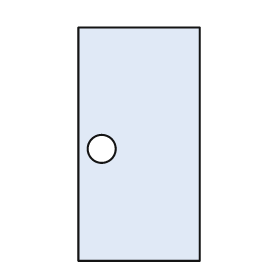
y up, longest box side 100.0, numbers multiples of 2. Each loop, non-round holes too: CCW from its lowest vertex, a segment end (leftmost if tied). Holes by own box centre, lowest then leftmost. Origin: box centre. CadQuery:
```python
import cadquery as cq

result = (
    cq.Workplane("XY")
    .moveTo(-26.0, -50.0)
    .lineTo(26.0, -50.0)
    .lineTo(26.0, 50.0)
    .lineTo(-26.0, 50.0)
    .close()
    .moveTo(-16.0, -2.0)
    .circle(6.0)
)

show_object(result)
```